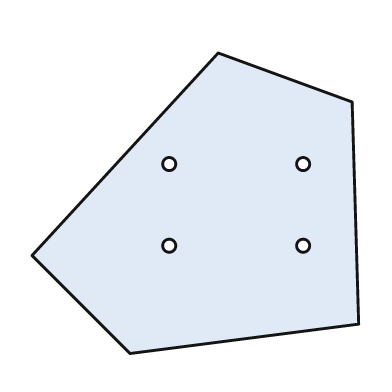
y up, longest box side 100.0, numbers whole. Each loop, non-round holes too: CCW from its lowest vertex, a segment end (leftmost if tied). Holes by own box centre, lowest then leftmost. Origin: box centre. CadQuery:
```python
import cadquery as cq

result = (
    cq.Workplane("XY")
    .moveTo(-20.0, -46.0)
    .lineTo(50.0, -37.0)
    .lineTo(48.0, 31.0)
    .lineTo(7.0, 46.0)
    .lineTo(-50.0, -16.0)
    .close()
    .moveTo(-8.0, -13.0)
    .circle(2.0)
    .moveTo(33.0, -13.0)
    .circle(2.0)
    .moveTo(-8.0, 12.0)
    .circle(2.0)
    .moveTo(33.0, 12.0)
    .circle(2.0)
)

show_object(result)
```